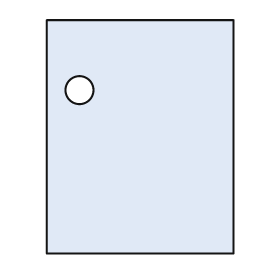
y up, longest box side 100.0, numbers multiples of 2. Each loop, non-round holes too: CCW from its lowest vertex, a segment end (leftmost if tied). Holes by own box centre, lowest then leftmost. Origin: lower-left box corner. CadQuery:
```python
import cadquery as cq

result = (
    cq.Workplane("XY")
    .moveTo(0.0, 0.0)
    .lineTo(80.0, 0.0)
    .lineTo(80.0, 100.0)
    .lineTo(0.0, 100.0)
    .close()
    .moveTo(14.0, 70.0)
    .circle(6.0)
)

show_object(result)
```